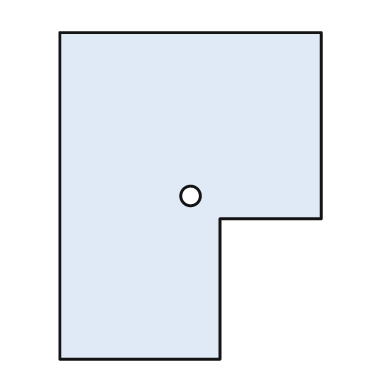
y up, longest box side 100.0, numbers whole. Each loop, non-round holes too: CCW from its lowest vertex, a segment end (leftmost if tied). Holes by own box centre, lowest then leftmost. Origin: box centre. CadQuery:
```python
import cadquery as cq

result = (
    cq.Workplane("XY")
    .moveTo(-40.0, -50.0)
    .lineTo(9.0, -50.0)
    .lineTo(9.0, -7.0)
    .lineTo(40.0, -7.0)
    .lineTo(40.0, 50.0)
    .lineTo(-40.0, 50.0)
    .close()
    .moveTo(0.0, 0.0)
    .circle(3.0)
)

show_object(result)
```